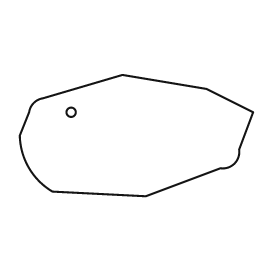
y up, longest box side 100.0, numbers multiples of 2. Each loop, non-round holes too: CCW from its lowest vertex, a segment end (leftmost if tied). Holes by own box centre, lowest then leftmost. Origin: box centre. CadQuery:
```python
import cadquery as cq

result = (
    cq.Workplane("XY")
    .moveTo(4.0, -26.0)
    .lineTo(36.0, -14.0)
    .threePointArc((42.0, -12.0), (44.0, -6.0))
    .lineTo(50.0, 10.0)
    .lineTo(30.0, 20.0)
    .lineTo(-6.0, 26.0)
    .lineTo(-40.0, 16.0)
    .threePointArc((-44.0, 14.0), (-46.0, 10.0))
    .lineTo(-50.0, 0.0)
    .threePointArc((-46.0, -14.0), (-36.0, -24.0))
    .close()
    .moveTo(-28.0, 10.0)
    .circle(2.0)
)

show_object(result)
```